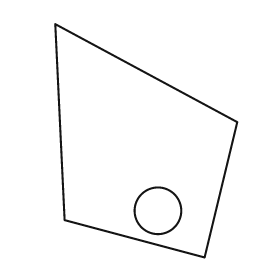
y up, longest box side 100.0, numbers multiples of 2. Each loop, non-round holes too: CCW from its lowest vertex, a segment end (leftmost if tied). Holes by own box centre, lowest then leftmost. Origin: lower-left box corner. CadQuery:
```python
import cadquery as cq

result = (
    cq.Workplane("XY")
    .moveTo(64.0, 0.0)
    .lineTo(78.0, 58.0)
    .lineTo(0.0, 100.0)
    .lineTo(4.0, 16.0)
    .close()
    .moveTo(44.0, 20.0)
    .circle(10.0)
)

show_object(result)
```